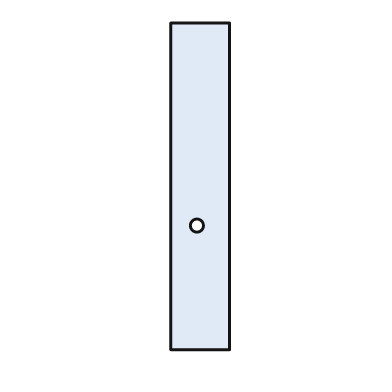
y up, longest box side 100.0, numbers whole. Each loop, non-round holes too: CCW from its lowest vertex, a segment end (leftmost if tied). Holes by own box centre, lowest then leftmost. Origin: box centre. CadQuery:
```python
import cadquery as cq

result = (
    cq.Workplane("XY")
    .moveTo(-9.0, -50.0)
    .lineTo(9.0, -50.0)
    .lineTo(9.0, 50.0)
    .lineTo(-9.0, 50.0)
    .close()
    .moveTo(-1.0, -12.0)
    .circle(2.0)
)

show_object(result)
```